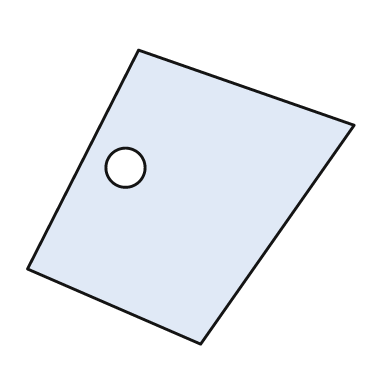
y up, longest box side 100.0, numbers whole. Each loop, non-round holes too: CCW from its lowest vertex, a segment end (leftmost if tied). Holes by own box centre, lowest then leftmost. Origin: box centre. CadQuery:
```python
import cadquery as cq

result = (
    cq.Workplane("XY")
    .moveTo(3.0, -45.0)
    .lineTo(50.0, 22.0)
    .lineTo(-16.0, 45.0)
    .lineTo(-50.0, -22.0)
    .close()
    .moveTo(-20.0, 9.0)
    .circle(6.0)
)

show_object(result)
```